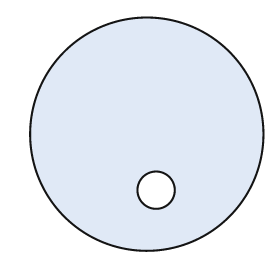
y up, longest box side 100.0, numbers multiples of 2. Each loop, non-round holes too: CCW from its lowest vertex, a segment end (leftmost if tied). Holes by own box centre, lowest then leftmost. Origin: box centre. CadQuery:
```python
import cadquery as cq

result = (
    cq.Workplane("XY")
    .moveTo(0.0, 0.0)
    .circle(50.0)
    .moveTo(4.0, -24.0)
    .circle(8.0)
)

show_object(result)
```